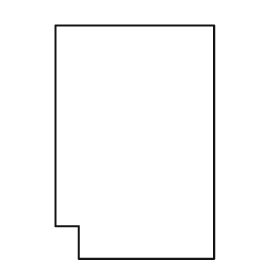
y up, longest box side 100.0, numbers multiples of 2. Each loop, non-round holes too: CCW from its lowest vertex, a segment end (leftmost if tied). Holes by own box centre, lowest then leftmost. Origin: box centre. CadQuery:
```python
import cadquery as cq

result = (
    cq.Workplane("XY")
    .moveTo(-24.0, -50.0)
    .lineTo(34.0, -50.0)
    .lineTo(34.0, 50.0)
    .lineTo(-34.0, 50.0)
    .lineTo(-34.0, -36.0)
    .lineTo(-24.0, -36.0)
    .close()
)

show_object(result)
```